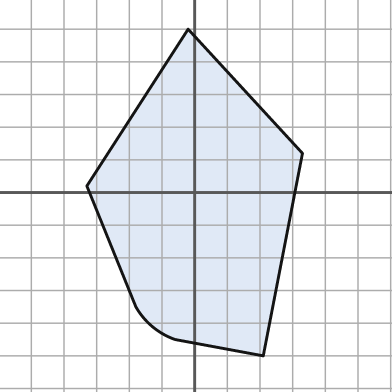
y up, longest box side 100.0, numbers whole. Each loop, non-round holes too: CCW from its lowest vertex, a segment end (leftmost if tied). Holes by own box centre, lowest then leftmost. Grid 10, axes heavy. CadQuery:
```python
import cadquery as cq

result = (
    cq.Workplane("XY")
    .moveTo(21.0, -50.0)
    .lineTo(33.0, 12.0)
    .lineTo(-2.0, 50.0)
    .lineTo(-33.0, 2.0)
    .lineTo(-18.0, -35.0)
    .threePointArc((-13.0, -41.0), (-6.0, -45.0))
    .close()
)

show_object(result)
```